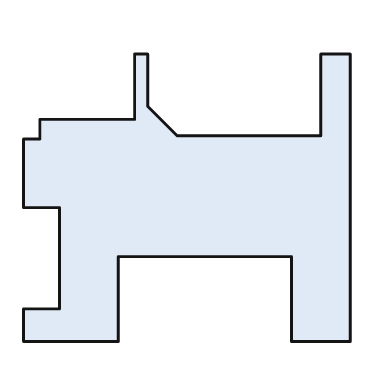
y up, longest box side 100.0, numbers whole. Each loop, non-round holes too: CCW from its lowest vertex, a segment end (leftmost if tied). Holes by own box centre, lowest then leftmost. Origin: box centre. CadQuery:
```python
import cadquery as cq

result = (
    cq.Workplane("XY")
    .moveTo(-50.0, -44.0)
    .lineTo(-21.0, -44.0)
    .lineTo(-21.0, -18.0)
    .lineTo(32.0, -18.0)
    .lineTo(32.0, -44.0)
    .lineTo(50.0, -44.0)
    .lineTo(50.0, 44.0)
    .lineTo(41.0, 44.0)
    .lineTo(41.0, 19.0)
    .lineTo(-3.0, 19.0)
    .lineTo(-12.0, 28.0)
    .lineTo(-12.0, 44.0)
    .lineTo(-16.0, 44.0)
    .lineTo(-16.0, 24.0)
    .lineTo(-45.0, 24.0)
    .lineTo(-45.0, 18.0)
    .lineTo(-50.0, 18.0)
    .lineTo(-50.0, -3.0)
    .lineTo(-39.0, -3.0)
    .lineTo(-39.0, -34.0)
    .lineTo(-50.0, -34.0)
    .close()
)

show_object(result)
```